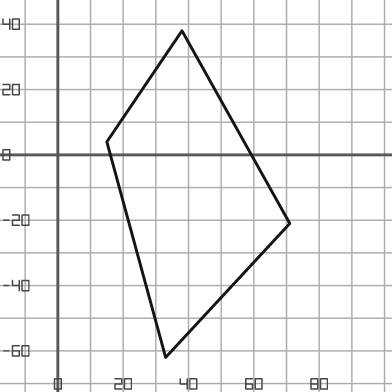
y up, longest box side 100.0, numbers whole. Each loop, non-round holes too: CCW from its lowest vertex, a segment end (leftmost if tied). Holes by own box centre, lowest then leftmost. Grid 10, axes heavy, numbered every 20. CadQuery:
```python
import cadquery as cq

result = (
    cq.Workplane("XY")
    .moveTo(33.0, -62.0)
    .lineTo(71.0, -21.0)
    .lineTo(38.0, 38.0)
    .lineTo(15.0, 4.0)
    .close()
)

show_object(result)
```